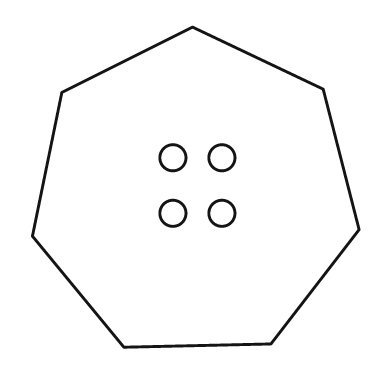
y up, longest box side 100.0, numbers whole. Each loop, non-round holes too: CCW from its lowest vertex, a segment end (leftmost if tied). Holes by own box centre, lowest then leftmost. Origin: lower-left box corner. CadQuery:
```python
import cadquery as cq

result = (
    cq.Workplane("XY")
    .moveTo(28.0, 0.0)
    .lineTo(73.0, 1.0)
    .lineTo(100.0, 36.0)
    .lineTo(89.0, 79.0)
    .lineTo(49.0, 98.0)
    .lineTo(9.0, 78.0)
    .lineTo(0.0, 34.0)
    .close()
    .moveTo(43.0, 41.0)
    .circle(4.0)
    .moveTo(58.0, 41.0)
    .circle(4.0)
    .moveTo(43.0, 58.0)
    .circle(4.0)
    .moveTo(58.0, 58.0)
    .circle(4.0)
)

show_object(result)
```